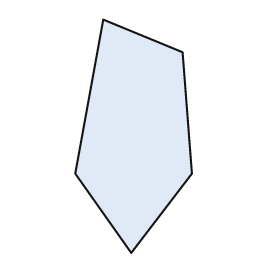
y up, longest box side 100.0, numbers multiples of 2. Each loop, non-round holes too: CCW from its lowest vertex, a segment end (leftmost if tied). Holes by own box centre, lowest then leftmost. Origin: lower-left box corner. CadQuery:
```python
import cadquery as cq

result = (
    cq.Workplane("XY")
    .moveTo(24.0, 0.0)
    .lineTo(50.0, 34.0)
    .lineTo(46.0, 86.0)
    .lineTo(12.0, 100.0)
    .lineTo(0.0, 34.0)
    .close()
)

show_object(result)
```